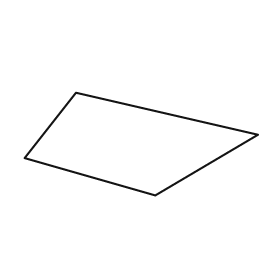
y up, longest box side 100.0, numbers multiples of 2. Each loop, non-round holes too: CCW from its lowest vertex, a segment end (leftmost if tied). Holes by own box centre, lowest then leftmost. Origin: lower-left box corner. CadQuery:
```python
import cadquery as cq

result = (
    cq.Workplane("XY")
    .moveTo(56.0, 0.0)
    .lineTo(100.0, 26.0)
    .lineTo(22.0, 44.0)
    .lineTo(0.0, 16.0)
    .close()
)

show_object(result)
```